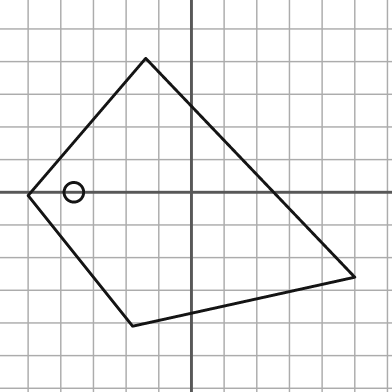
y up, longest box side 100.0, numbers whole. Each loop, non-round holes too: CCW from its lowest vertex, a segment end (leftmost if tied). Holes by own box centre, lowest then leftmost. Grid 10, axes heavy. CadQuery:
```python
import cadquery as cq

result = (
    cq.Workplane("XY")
    .moveTo(-18.0, -41.0)
    .lineTo(50.0, -26.0)
    .lineTo(-14.0, 41.0)
    .lineTo(-50.0, -1.0)
    .close()
    .moveTo(-36.0, 0.0)
    .circle(3.0)
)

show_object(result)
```